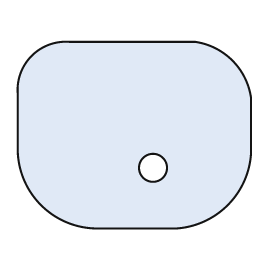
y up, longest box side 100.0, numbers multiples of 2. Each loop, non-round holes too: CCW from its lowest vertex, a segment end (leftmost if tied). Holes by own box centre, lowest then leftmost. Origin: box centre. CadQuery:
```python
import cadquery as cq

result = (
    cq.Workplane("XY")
    .moveTo(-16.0, -40.0)
    .lineTo(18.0, -40.0)
    .threePointArc((40.0, -30.0), (50.0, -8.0))
    .lineTo(50.0, 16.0)
    .threePointArc((42.0, 32.0), (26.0, 40.0))
    .lineTo(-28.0, 40.0)
    .threePointArc((-44.0, 34.0), (-50.0, 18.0))
    .lineTo(-50.0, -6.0)
    .threePointArc((-40.0, -30.0), (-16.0, -40.0))
    .close()
    .moveTo(8.0, -14.0)
    .circle(6.0)
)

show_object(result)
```